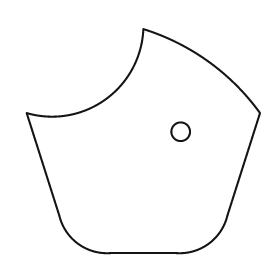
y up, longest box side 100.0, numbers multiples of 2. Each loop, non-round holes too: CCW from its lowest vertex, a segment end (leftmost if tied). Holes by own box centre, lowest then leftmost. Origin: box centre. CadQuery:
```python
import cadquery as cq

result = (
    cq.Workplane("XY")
    .moveTo(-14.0, -48.0)
    .lineTo(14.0, -48.0)
    .threePointArc((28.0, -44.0), (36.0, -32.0))
    .lineTo(50.0, 12.0)
    .threePointArc((28.0, 34.0), (0.0, 48.0))
    .threePointArc((-16.0, 18.0), (-50.0, 12.0))
    .lineTo(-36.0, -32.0)
    .threePointArc((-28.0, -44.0), (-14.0, -48.0))
    .close()
    .moveTo(16.0, 4.0)
    .circle(4.0)
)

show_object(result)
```